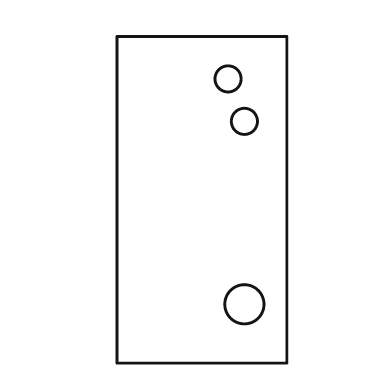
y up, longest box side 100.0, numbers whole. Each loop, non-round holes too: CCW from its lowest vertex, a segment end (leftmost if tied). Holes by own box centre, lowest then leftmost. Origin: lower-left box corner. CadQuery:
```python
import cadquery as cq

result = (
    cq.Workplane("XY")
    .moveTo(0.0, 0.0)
    .lineTo(52.0, 0.0)
    .lineTo(52.0, 100.0)
    .lineTo(0.0, 100.0)
    .close()
    .moveTo(39.0, 18.0)
    .circle(6.0)
    .moveTo(39.0, 74.0)
    .circle(4.0)
    .moveTo(34.0, 87.0)
    .circle(4.0)
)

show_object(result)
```